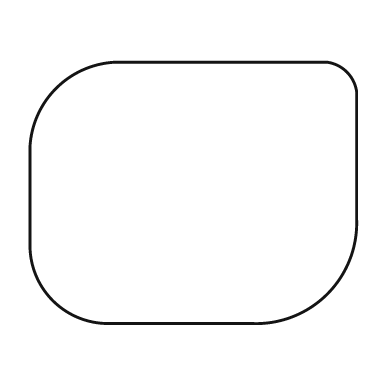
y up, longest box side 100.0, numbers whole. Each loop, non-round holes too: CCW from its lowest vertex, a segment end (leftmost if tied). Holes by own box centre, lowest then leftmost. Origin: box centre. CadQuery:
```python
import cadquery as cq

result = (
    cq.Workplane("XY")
    .moveTo(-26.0, -40.0)
    .lineTo(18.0, -40.0)
    .threePointArc((41.0, -31.0), (50.0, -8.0))
    .lineTo(50.0, 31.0)
    .threePointArc((47.0, 37.0), (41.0, 40.0))
    .lineTo(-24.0, 40.0)
    .threePointArc((-42.0, 32.0), (-50.0, 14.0))
    .lineTo(-50.0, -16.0)
    .threePointArc((-43.0, -33.0), (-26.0, -40.0))
    .close()
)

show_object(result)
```